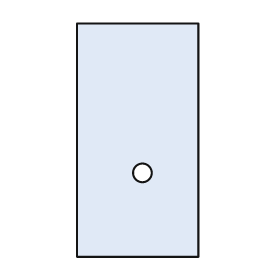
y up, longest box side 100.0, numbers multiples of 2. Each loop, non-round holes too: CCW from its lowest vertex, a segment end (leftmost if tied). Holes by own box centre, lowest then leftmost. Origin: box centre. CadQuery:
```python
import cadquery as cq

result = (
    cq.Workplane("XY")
    .moveTo(-26.0, -50.0)
    .lineTo(26.0, -50.0)
    .lineTo(26.0, 50.0)
    .lineTo(-26.0, 50.0)
    .close()
    .moveTo(2.0, -14.0)
    .circle(4.0)
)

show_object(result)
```